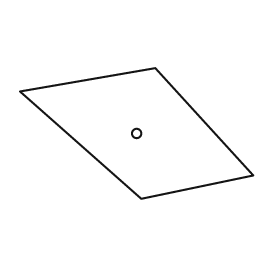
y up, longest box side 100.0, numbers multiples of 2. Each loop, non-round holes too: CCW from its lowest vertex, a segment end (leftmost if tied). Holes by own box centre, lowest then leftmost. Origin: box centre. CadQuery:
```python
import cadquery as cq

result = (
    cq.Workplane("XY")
    .moveTo(2.0, -28.0)
    .lineTo(50.0, -18.0)
    .lineTo(8.0, 28.0)
    .lineTo(-50.0, 18.0)
    .close()
    .moveTo(0.0, 0.0)
    .circle(2.0)
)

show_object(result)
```